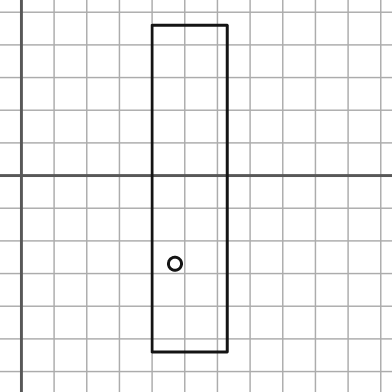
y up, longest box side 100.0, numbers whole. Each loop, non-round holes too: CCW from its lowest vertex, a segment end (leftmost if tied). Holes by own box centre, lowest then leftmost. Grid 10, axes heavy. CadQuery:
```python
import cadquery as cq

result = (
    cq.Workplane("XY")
    .moveTo(40.0, -54.0)
    .lineTo(63.0, -54.0)
    .lineTo(63.0, 46.0)
    .lineTo(40.0, 46.0)
    .close()
    .moveTo(47.0, -27.0)
    .circle(2.0)
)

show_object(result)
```